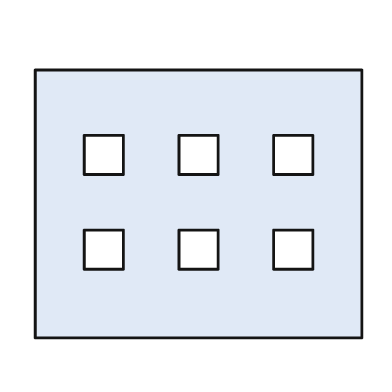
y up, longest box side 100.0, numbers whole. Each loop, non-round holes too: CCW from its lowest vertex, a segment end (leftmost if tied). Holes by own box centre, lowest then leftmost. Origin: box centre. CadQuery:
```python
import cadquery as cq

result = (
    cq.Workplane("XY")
    .moveTo(-50.0, -41.0)
    .lineTo(50.0, -41.0)
    .lineTo(50.0, 41.0)
    .lineTo(-50.0, 41.0)
    .close()
    .moveTo(-35.0, -20.0)
    .lineTo(-23.0, -20.0)
    .lineTo(-23.0, -8.0)
    .lineTo(-35.0, -8.0)
    .close()
    .moveTo(-6.0, -20.0)
    .lineTo(6.0, -20.0)
    .lineTo(6.0, -8.0)
    .lineTo(-6.0, -8.0)
    .close()
    .moveTo(23.0, -20.0)
    .lineTo(35.0, -20.0)
    .lineTo(35.0, -8.0)
    .lineTo(23.0, -8.0)
    .close()
    .moveTo(-35.0, 9.0)
    .lineTo(-23.0, 9.0)
    .lineTo(-23.0, 21.0)
    .lineTo(-35.0, 21.0)
    .close()
    .moveTo(-6.0, 9.0)
    .lineTo(6.0, 9.0)
    .lineTo(6.0, 21.0)
    .lineTo(-6.0, 21.0)
    .close()
    .moveTo(23.0, 9.0)
    .lineTo(35.0, 9.0)
    .lineTo(35.0, 21.0)
    .lineTo(23.0, 21.0)
    .close()
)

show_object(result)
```